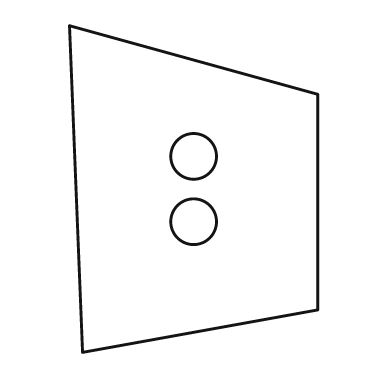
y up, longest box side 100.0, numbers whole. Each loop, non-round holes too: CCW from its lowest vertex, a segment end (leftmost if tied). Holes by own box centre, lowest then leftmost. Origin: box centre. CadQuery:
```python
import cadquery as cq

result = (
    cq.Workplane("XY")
    .moveTo(-34.0, -50.0)
    .lineTo(38.0, -37.0)
    .lineTo(38.0, 29.0)
    .lineTo(-38.0, 50.0)
    .close()
    .moveTo(0.0, -10.0)
    .circle(7.0)
    .moveTo(0.0, 10.0)
    .circle(7.0)
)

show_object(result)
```